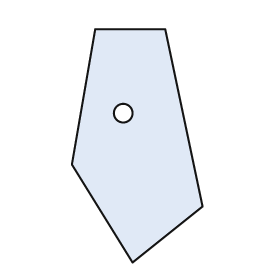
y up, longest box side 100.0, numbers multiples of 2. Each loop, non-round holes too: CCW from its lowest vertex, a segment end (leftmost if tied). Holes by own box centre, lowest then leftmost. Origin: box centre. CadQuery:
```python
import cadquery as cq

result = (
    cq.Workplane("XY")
    .moveTo(-2.0, -50.0)
    .lineTo(28.0, -26.0)
    .lineTo(12.0, 50.0)
    .lineTo(-18.0, 50.0)
    .lineTo(-28.0, -8.0)
    .close()
    .moveTo(-6.0, 14.0)
    .circle(4.0)
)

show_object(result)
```